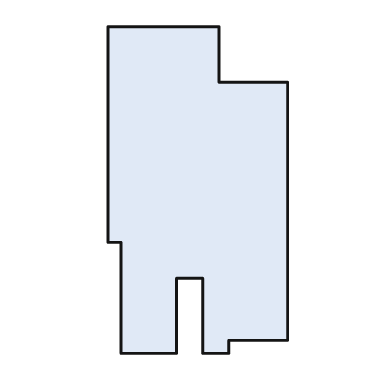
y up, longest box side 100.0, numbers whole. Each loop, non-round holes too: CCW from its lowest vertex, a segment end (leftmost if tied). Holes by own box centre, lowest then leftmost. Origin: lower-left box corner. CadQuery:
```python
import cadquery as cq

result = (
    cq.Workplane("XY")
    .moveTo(4.0, 0.0)
    .lineTo(21.0, 0.0)
    .lineTo(21.0, 23.0)
    .lineTo(29.0, 23.0)
    .lineTo(29.0, 0.0)
    .lineTo(37.0, 0.0)
    .lineTo(37.0, 4.0)
    .lineTo(55.0, 4.0)
    .lineTo(55.0, 83.0)
    .lineTo(34.0, 83.0)
    .lineTo(34.0, 100.0)
    .lineTo(0.0, 100.0)
    .lineTo(0.0, 34.0)
    .lineTo(4.0, 34.0)
    .close()
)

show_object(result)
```